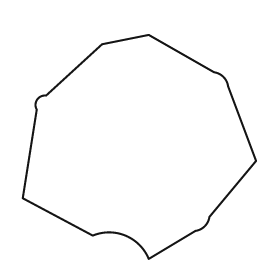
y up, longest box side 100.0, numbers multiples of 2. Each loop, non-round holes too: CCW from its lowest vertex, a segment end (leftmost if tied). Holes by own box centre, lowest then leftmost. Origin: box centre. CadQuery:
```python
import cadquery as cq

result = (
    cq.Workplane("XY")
    .moveTo(4.0, -48.0)
    .lineTo(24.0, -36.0)
    .threePointArc((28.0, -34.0), (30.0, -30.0))
    .lineTo(50.0, -6.0)
    .lineTo(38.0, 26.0)
    .threePointArc((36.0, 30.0), (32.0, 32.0))
    .lineTo(4.0, 48.0)
    .lineTo(-16.0, 44.0)
    .lineTo(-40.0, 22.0)
    .threePointArc((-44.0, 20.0), (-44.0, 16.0))
    .lineTo(-50.0, -22.0)
    .lineTo(-20.0, -38.0)
    .threePointArc((-6.0, -38.0), (4.0, -48.0))
    .close()
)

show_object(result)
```